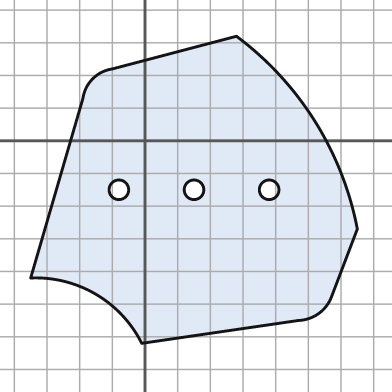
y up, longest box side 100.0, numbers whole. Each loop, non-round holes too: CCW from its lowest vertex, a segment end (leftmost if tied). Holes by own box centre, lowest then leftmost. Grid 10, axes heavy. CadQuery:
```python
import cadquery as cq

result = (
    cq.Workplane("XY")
    .moveTo(-1.0, -62.0)
    .lineTo(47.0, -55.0)
    .threePointArc((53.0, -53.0), (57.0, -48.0))
    .lineTo(65.0, -27.0)
    .threePointArc((52.0, 6.0), (28.0, 32.0))
    .lineTo(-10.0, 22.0)
    .threePointArc((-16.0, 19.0), (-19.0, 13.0))
    .lineTo(-35.0, -42.0)
    .threePointArc((-15.0, -47.0), (-1.0, -62.0))
    .close()
    .moveTo(-8.0, -15.0)
    .circle(3.0)
    .moveTo(15.0, -15.0)
    .circle(3.0)
    .moveTo(38.0, -15.0)
    .circle(3.0)
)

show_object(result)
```